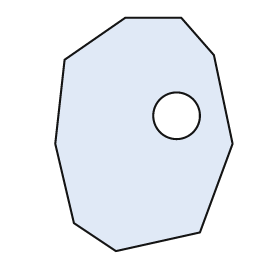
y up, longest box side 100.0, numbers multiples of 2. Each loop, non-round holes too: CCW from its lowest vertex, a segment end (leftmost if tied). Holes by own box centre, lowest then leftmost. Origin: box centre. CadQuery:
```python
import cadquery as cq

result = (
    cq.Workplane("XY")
    .moveTo(-12.0, -50.0)
    .lineTo(24.0, -42.0)
    .lineTo(38.0, -4.0)
    .lineTo(30.0, 34.0)
    .lineTo(16.0, 50.0)
    .lineTo(-8.0, 50.0)
    .lineTo(-34.0, 32.0)
    .lineTo(-38.0, -4.0)
    .lineTo(-30.0, -38.0)
    .close()
    .moveTo(14.0, 8.0)
    .circle(10.0)
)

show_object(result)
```